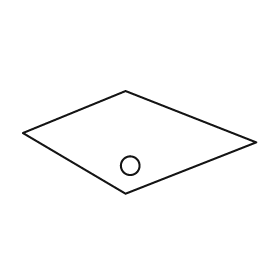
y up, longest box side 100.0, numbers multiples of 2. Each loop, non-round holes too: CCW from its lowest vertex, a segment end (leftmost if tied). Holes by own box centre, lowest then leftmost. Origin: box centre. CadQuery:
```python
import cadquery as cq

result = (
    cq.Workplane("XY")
    .moveTo(-6.0, -22.0)
    .lineTo(50.0, 0.0)
    .lineTo(-6.0, 22.0)
    .lineTo(-50.0, 4.0)
    .close()
    .moveTo(-4.0, -10.0)
    .circle(4.0)
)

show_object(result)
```